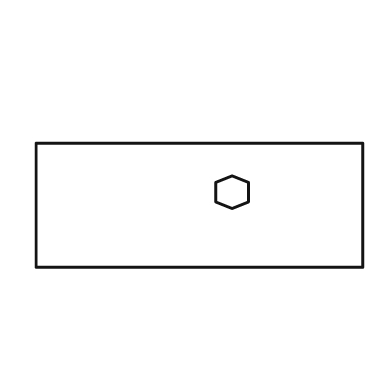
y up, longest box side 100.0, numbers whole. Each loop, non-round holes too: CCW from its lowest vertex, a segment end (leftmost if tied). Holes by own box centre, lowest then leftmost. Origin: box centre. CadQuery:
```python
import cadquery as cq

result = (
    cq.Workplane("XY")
    .moveTo(-50.0, -19.0)
    .lineTo(50.0, -19.0)
    .lineTo(50.0, 19.0)
    .lineTo(-50.0, 19.0)
    .close()
    .moveTo(10.0, -1.0)
    .lineTo(15.0, 1.0)
    .lineTo(15.0, 7.0)
    .lineTo(10.0, 9.0)
    .lineTo(5.0, 7.0)
    .lineTo(5.0, 1.0)
    .close()
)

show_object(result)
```